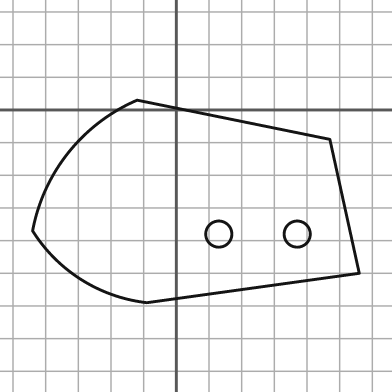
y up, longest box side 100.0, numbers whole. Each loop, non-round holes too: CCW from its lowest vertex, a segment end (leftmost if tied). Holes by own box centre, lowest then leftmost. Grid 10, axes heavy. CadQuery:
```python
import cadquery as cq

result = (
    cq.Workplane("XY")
    .moveTo(-9.0, -59.0)
    .lineTo(56.0, -50.0)
    .lineTo(47.0, -9.0)
    .lineTo(-12.0, 3.0)
    .threePointArc((-33.0, -13.0), (-44.0, -37.0))
    .threePointArc((-29.0, -52.0), (-9.0, -59.0))
    .close()
    .moveTo(13.0, -38.0)
    .circle(4.0)
    .moveTo(37.0, -38.0)
    .circle(4.0)
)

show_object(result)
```